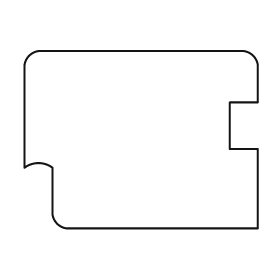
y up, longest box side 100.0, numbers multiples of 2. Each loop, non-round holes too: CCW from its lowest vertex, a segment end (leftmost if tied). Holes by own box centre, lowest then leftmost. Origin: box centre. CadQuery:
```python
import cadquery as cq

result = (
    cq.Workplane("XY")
    .moveTo(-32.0, -38.0)
    .lineTo(50.0, -38.0)
    .lineTo(50.0, -4.0)
    .lineTo(38.0, -4.0)
    .lineTo(38.0, 16.0)
    .lineTo(50.0, 16.0)
    .lineTo(50.0, 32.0)
    .threePointArc((48.0, 36.0), (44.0, 38.0))
    .lineTo(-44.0, 38.0)
    .threePointArc((-48.0, 36.0), (-50.0, 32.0))
    .lineTo(-50.0, -12.0)
    .threePointArc((-44.0, -10.0), (-38.0, -12.0))
    .lineTo(-38.0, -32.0)
    .threePointArc((-36.0, -36.0), (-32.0, -38.0))
    .close()
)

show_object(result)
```